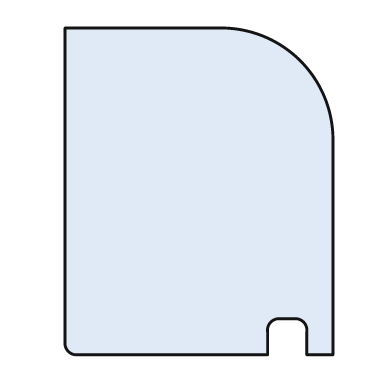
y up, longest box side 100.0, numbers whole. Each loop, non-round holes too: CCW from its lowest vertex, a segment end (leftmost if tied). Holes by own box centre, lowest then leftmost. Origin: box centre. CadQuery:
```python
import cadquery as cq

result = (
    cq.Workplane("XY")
    .moveTo(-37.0, -50.0)
    .lineTo(21.0, -50.0)
    .lineTo(21.0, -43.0)
    .threePointArc((22.0, -40.0), (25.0, -39.0))
    .lineTo(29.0, -39.0)
    .threePointArc((32.0, -40.0), (33.0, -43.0))
    .lineTo(33.0, -50.0)
    .lineTo(41.0, -50.0)
    .lineTo(41.0, 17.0)
    .threePointArc((31.0, 40.0), (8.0, 50.0))
    .lineTo(-41.0, 50.0)
    .lineTo(-41.0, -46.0)
    .threePointArc((-40.0, -49.0), (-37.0, -50.0))
    .close()
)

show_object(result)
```